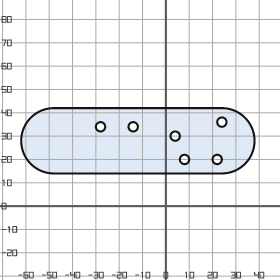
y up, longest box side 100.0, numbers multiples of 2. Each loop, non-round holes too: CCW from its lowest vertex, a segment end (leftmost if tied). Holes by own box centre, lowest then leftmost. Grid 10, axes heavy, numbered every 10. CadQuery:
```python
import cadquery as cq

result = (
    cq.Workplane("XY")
    .moveTo(-48.0, 14.0)
    .lineTo(24.0, 14.0)
    .threePointArc((38.0, 28.0), (24.0, 42.0))
    .lineTo(-48.0, 42.0)
    .threePointArc((-62.0, 28.0), (-48.0, 14.0))
    .close()
    .moveTo(8.0, 20.0)
    .circle(2.0)
    .moveTo(22.0, 20.0)
    .circle(2.0)
    .moveTo(4.0, 30.0)
    .circle(2.0)
    .moveTo(-28.0, 34.0)
    .circle(2.0)
    .moveTo(-14.0, 34.0)
    .circle(2.0)
    .moveTo(24.0, 36.0)
    .circle(2.0)
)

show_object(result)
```